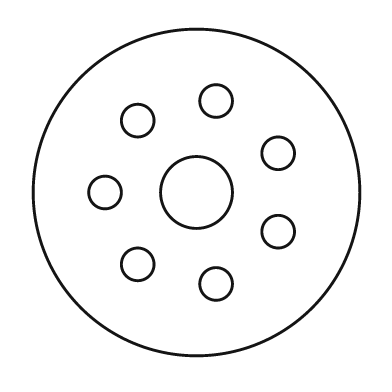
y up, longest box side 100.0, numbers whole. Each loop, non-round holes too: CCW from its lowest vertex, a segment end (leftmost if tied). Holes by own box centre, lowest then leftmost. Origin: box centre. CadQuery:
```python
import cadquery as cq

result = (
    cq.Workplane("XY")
    .moveTo(0.0, 0.0)
    .circle(50.0)
    .moveTo(6.0, -28.0)
    .circle(5.0)
    .moveTo(-18.0, -22.0)
    .circle(5.0)
    .moveTo(25.0, -12.0)
    .circle(5.0)
    .moveTo(-28.0, 0.0)
    .circle(5.0)
    .moveTo(0.0, 0.0)
    .circle(11.0)
    .moveTo(25.0, 12.0)
    .circle(5.0)
    .moveTo(-18.0, 22.0)
    .circle(5.0)
    .moveTo(6.0, 28.0)
    .circle(5.0)
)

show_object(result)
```